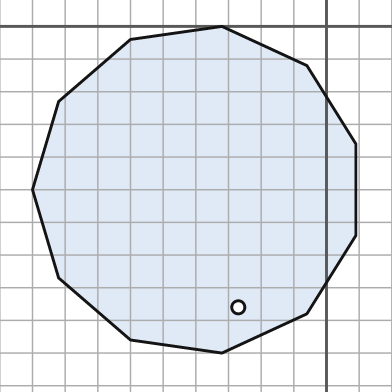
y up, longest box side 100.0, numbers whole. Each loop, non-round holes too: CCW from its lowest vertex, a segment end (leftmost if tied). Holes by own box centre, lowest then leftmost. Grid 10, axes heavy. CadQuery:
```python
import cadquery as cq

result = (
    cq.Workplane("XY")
    .moveTo(-32.0, -100.0)
    .lineTo(-6.0, -88.0)
    .lineTo(9.0, -64.0)
    .lineTo(9.0, -36.0)
    .lineTo(-6.0, -12.0)
    .lineTo(-32.0, 0.0)
    .lineTo(-60.0, -4.0)
    .lineTo(-82.0, -23.0)
    .lineTo(-90.0, -50.0)
    .lineTo(-82.0, -77.0)
    .lineTo(-60.0, -96.0)
    .close()
    .moveTo(-27.0, -86.0)
    .circle(2.0)
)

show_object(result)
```